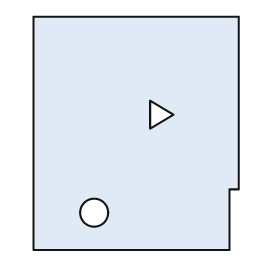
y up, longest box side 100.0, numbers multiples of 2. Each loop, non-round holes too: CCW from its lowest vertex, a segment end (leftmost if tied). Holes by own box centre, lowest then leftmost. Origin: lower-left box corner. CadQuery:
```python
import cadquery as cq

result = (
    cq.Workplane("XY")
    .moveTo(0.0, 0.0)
    .lineTo(84.0, 0.0)
    .lineTo(84.0, 26.0)
    .lineTo(88.0, 26.0)
    .lineTo(88.0, 100.0)
    .lineTo(0.0, 100.0)
    .close()
    .moveTo(26.0, 16.0)
    .circle(6.0)
    .moveTo(50.0, 52.0)
    .lineTo(60.0, 58.0)
    .lineTo(50.0, 64.0)
    .close()
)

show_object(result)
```